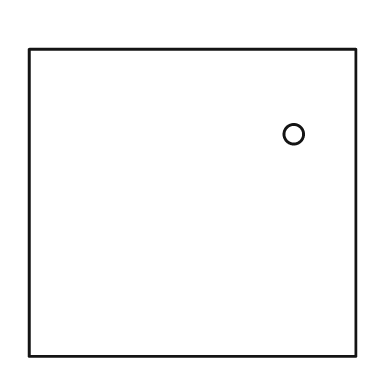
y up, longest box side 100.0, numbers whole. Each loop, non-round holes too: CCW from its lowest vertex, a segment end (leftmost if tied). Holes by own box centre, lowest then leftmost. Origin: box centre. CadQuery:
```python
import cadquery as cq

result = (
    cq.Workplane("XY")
    .moveTo(-50.0, -47.0)
    .lineTo(50.0, -47.0)
    .lineTo(50.0, 47.0)
    .lineTo(-50.0, 47.0)
    .close()
    .moveTo(31.0, 21.0)
    .circle(3.0)
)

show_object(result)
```